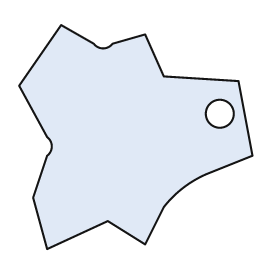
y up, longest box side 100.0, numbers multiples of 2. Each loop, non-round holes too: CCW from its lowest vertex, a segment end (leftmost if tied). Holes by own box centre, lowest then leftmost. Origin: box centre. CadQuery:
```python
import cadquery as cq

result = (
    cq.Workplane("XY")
    .moveTo(-38.0, -48.0)
    .lineTo(-12.0, -36.0)
    .lineTo(4.0, -46.0)
    .lineTo(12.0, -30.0)
    .threePointArc((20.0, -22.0), (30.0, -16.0))
    .lineTo(50.0, -8.0)
    .lineTo(44.0, 24.0)
    .lineTo(12.0, 26.0)
    .lineTo(4.0, 44.0)
    .lineTo(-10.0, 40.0)
    .threePointArc((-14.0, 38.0), (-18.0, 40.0))
    .lineTo(-32.0, 48.0)
    .lineTo(-50.0, 22.0)
    .lineTo(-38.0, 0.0)
    .threePointArc((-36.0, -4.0), (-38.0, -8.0))
    .lineTo(-44.0, -26.0)
    .close()
    .moveTo(36.0, 10.0)
    .circle(6.0)
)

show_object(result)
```